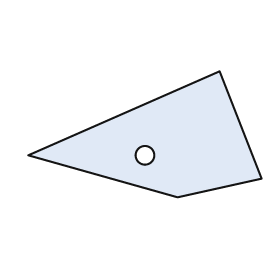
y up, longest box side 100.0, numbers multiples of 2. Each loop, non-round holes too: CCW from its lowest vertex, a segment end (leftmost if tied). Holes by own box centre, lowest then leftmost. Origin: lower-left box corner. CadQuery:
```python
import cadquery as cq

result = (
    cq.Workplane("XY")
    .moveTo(64.0, 0.0)
    .lineTo(100.0, 8.0)
    .lineTo(82.0, 54.0)
    .lineTo(0.0, 18.0)
    .close()
    .moveTo(50.0, 18.0)
    .circle(4.0)
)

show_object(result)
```